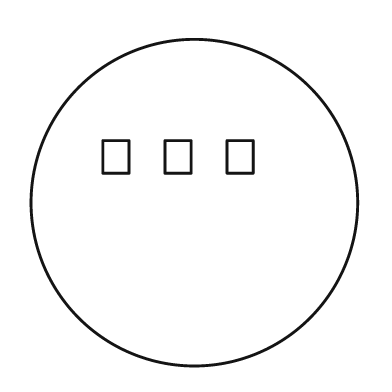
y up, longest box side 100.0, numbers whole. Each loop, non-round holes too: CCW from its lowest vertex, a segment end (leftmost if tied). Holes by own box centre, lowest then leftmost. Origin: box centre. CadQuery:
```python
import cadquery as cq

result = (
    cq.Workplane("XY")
    .moveTo(0.0, 0.0)
    .circle(50.0)
    .moveTo(-28.0, 9.0)
    .lineTo(-20.0, 9.0)
    .lineTo(-20.0, 19.0)
    .lineTo(-28.0, 19.0)
    .close()
    .moveTo(-9.0, 9.0)
    .lineTo(-1.0, 9.0)
    .lineTo(-1.0, 19.0)
    .lineTo(-9.0, 19.0)
    .close()
    .moveTo(10.0, 9.0)
    .lineTo(18.0, 9.0)
    .lineTo(18.0, 19.0)
    .lineTo(10.0, 19.0)
    .close()
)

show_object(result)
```